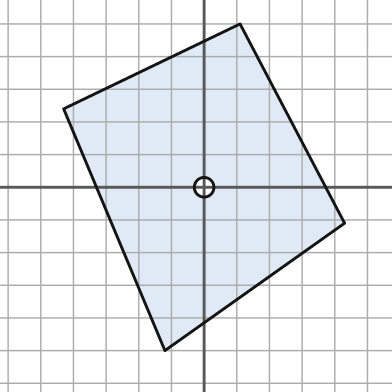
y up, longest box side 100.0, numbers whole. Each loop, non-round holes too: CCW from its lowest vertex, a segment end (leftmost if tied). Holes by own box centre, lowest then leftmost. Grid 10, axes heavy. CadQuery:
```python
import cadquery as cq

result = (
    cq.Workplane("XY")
    .moveTo(-12.0, -50.0)
    .lineTo(43.0, -11.0)
    .lineTo(11.0, 50.0)
    .lineTo(-43.0, 24.0)
    .close()
    .moveTo(0.0, 0.0)
    .circle(3.0)
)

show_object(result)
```